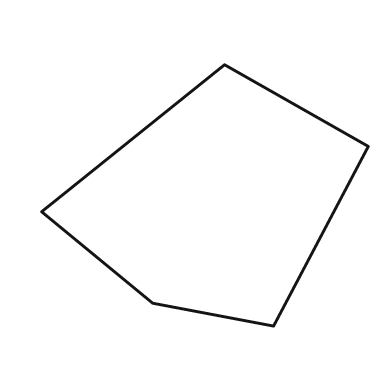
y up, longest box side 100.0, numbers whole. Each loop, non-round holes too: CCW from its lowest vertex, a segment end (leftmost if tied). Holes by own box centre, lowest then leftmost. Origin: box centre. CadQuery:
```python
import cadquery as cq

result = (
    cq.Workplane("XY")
    .moveTo(21.0, -40.0)
    .lineTo(50.0, 15.0)
    .lineTo(6.0, 40.0)
    .lineTo(-50.0, -5.0)
    .lineTo(-16.0, -33.0)
    .close()
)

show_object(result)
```